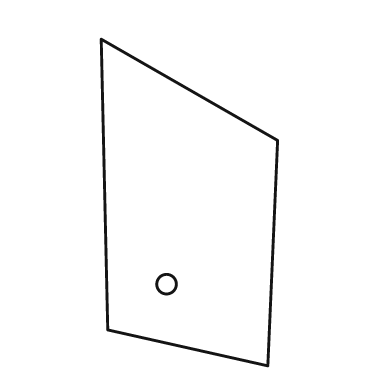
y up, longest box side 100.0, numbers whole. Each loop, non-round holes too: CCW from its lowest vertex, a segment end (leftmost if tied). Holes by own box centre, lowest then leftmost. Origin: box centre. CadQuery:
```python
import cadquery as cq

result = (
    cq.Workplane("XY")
    .moveTo(24.0, -50.0)
    .lineTo(27.0, 19.0)
    .lineTo(-27.0, 50.0)
    .lineTo(-25.0, -39.0)
    .close()
    .moveTo(-7.0, -25.0)
    .circle(3.0)
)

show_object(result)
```